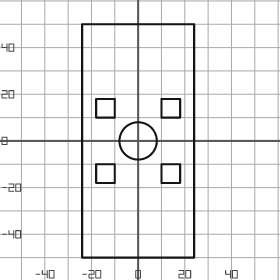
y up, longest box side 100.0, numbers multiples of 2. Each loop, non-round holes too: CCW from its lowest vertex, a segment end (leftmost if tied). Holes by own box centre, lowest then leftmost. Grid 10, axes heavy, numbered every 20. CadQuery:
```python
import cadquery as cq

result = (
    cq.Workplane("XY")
    .moveTo(-24.0, -50.0)
    .lineTo(24.0, -50.0)
    .lineTo(24.0, 50.0)
    .lineTo(-24.0, 50.0)
    .close()
    .moveTo(-18.0, -18.0)
    .lineTo(-10.0, -18.0)
    .lineTo(-10.0, -10.0)
    .lineTo(-18.0, -10.0)
    .close()
    .moveTo(10.0, -18.0)
    .lineTo(18.0, -18.0)
    .lineTo(18.0, -10.0)
    .lineTo(10.0, -10.0)
    .close()
    .moveTo(0.0, 0.0)
    .circle(8.0)
    .moveTo(-18.0, 10.0)
    .lineTo(-10.0, 10.0)
    .lineTo(-10.0, 18.0)
    .lineTo(-18.0, 18.0)
    .close()
    .moveTo(10.0, 10.0)
    .lineTo(18.0, 10.0)
    .lineTo(18.0, 18.0)
    .lineTo(10.0, 18.0)
    .close()
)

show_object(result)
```